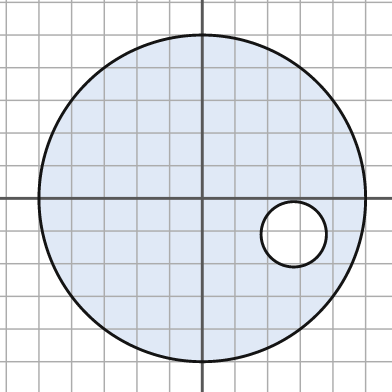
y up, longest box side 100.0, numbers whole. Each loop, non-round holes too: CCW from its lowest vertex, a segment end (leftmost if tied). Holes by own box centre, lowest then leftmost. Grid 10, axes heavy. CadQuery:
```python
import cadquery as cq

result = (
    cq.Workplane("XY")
    .moveTo(0.0, 0.0)
    .circle(50.0)
    .moveTo(28.0, -11.0)
    .circle(10.0)
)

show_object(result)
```